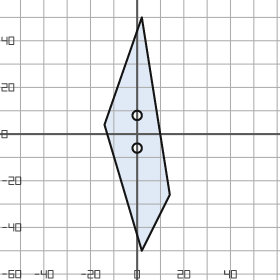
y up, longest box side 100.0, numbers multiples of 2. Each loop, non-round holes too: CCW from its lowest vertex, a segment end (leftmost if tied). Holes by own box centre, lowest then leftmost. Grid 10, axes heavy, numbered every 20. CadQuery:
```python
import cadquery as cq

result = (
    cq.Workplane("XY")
    .moveTo(2.0, -50.0)
    .lineTo(14.0, -26.0)
    .lineTo(2.0, 50.0)
    .lineTo(-14.0, 4.0)
    .close()
    .moveTo(0.0, -6.0)
    .circle(2.0)
    .moveTo(0.0, 8.0)
    .circle(2.0)
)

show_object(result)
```